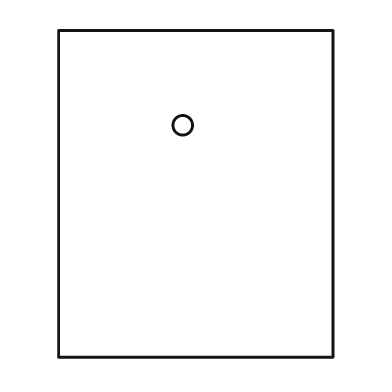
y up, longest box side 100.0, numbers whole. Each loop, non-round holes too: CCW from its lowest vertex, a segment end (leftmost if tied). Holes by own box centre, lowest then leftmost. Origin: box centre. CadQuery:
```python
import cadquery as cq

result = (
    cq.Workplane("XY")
    .moveTo(-42.0, -50.0)
    .lineTo(42.0, -50.0)
    .lineTo(42.0, 50.0)
    .lineTo(-42.0, 50.0)
    .close()
    .moveTo(-4.0, 21.0)
    .circle(3.0)
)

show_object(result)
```